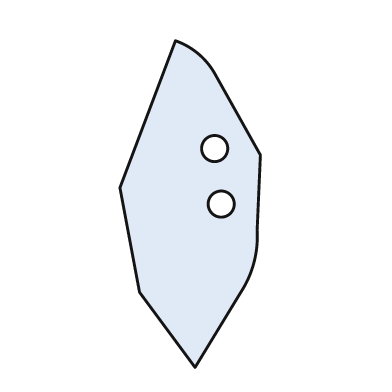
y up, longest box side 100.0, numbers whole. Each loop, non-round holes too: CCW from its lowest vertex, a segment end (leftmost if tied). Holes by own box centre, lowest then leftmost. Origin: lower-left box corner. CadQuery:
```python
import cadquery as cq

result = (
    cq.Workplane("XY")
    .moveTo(23.0, 0.0)
    .lineTo(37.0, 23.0)
    .threePointArc((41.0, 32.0), (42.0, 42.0))
    .lineTo(43.0, 65.0)
    .lineTo(29.0, 90.0)
    .threePointArc((24.0, 96.0), (17.0, 100.0))
    .lineTo(0.0, 55.0)
    .lineTo(6.0, 23.0)
    .close()
    .moveTo(31.0, 50.0)
    .circle(4.0)
    .moveTo(29.0, 67.0)
    .circle(4.0)
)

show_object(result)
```